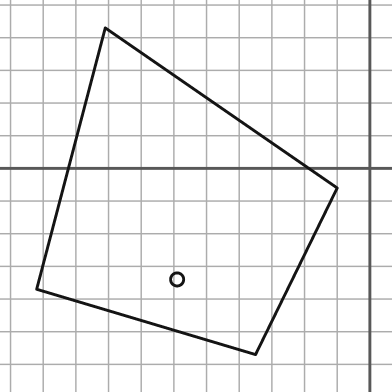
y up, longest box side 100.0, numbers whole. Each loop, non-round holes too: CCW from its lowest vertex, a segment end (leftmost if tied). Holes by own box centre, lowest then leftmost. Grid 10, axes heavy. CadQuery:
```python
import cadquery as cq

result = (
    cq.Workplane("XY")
    .moveTo(-35.0, -57.0)
    .lineTo(-10.0, -6.0)
    .lineTo(-81.0, 43.0)
    .lineTo(-102.0, -37.0)
    .close()
    .moveTo(-59.0, -34.0)
    .circle(2.0)
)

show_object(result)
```